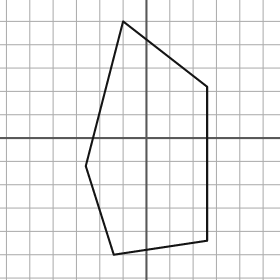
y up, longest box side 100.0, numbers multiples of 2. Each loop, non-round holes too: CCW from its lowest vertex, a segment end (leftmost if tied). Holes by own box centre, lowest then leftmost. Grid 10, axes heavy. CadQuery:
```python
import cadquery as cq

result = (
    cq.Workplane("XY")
    .moveTo(-14.0, -50.0)
    .lineTo(26.0, -44.0)
    .lineTo(26.0, 22.0)
    .lineTo(-10.0, 50.0)
    .lineTo(-26.0, -12.0)
    .close()
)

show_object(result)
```